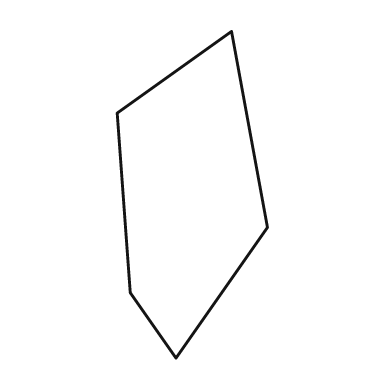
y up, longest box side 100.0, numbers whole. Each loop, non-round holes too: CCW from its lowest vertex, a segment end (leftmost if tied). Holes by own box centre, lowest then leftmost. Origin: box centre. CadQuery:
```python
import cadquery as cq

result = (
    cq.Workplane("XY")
    .moveTo(-5.0, -50.0)
    .lineTo(23.0, -10.0)
    .lineTo(12.0, 50.0)
    .lineTo(-23.0, 25.0)
    .lineTo(-19.0, -30.0)
    .close()
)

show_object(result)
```